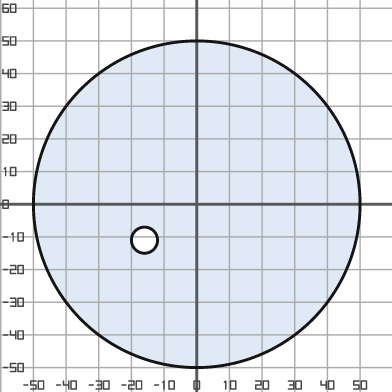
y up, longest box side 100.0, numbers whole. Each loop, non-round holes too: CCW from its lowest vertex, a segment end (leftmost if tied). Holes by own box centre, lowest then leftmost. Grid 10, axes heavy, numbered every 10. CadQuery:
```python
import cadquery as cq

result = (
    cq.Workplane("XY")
    .moveTo(0.0, 0.0)
    .circle(50.0)
    .moveTo(-16.0, -11.0)
    .circle(4.0)
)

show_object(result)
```